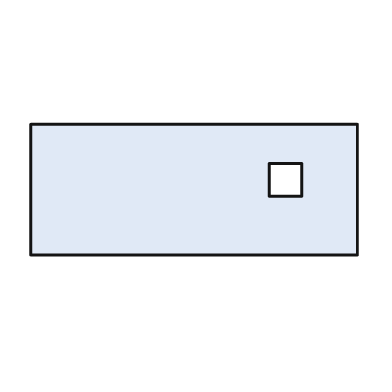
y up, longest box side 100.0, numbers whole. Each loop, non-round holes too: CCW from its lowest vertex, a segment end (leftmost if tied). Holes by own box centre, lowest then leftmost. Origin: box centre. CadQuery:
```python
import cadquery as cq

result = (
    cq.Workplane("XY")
    .moveTo(-50.0, -20.0)
    .lineTo(50.0, -20.0)
    .lineTo(50.0, 20.0)
    .lineTo(-50.0, 20.0)
    .close()
    .moveTo(23.0, -2.0)
    .lineTo(33.0, -2.0)
    .lineTo(33.0, 8.0)
    .lineTo(23.0, 8.0)
    .close()
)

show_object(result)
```